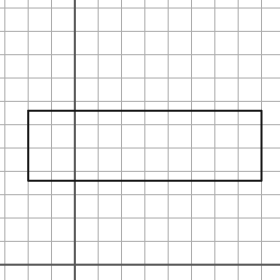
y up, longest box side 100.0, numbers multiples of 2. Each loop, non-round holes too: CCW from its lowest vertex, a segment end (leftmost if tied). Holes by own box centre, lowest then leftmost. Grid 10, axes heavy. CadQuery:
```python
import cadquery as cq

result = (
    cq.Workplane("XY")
    .moveTo(-20.0, 36.0)
    .lineTo(80.0, 36.0)
    .lineTo(80.0, 66.0)
    .lineTo(-20.0, 66.0)
    .close()
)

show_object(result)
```